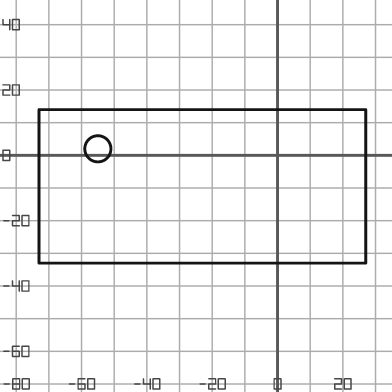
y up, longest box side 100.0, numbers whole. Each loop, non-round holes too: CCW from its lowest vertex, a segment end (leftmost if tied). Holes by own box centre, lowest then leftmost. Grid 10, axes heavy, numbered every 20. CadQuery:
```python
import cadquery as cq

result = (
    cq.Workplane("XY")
    .moveTo(-73.0, -33.0)
    .lineTo(27.0, -33.0)
    .lineTo(27.0, 14.0)
    .lineTo(-73.0, 14.0)
    .close()
    .moveTo(-55.0, 2.0)
    .circle(4.0)
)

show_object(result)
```